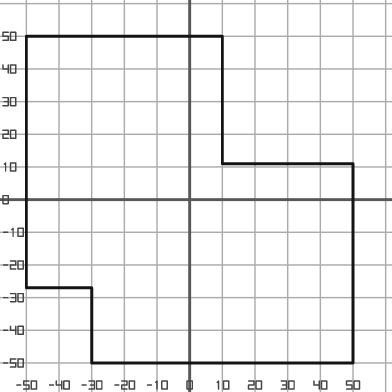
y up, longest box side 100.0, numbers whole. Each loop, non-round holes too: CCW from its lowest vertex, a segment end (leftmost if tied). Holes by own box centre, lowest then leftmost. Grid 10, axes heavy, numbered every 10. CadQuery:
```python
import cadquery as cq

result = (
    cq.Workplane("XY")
    .moveTo(-30.0, -50.0)
    .lineTo(50.0, -50.0)
    .lineTo(50.0, 11.0)
    .lineTo(10.0, 11.0)
    .lineTo(10.0, 50.0)
    .lineTo(-50.0, 50.0)
    .lineTo(-50.0, -27.0)
    .lineTo(-30.0, -27.0)
    .close()
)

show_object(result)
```